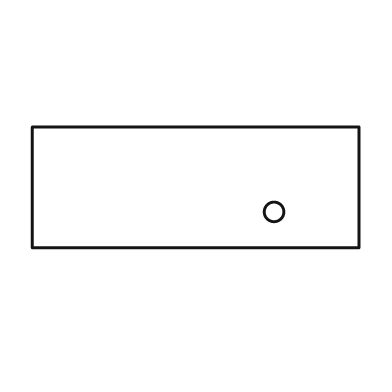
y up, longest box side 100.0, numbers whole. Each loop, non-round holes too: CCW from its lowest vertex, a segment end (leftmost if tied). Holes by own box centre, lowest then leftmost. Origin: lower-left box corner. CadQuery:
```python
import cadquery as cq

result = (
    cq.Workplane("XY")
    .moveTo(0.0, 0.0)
    .lineTo(100.0, 0.0)
    .lineTo(100.0, 37.0)
    .lineTo(0.0, 37.0)
    .close()
    .moveTo(74.0, 11.0)
    .circle(3.0)
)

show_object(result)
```